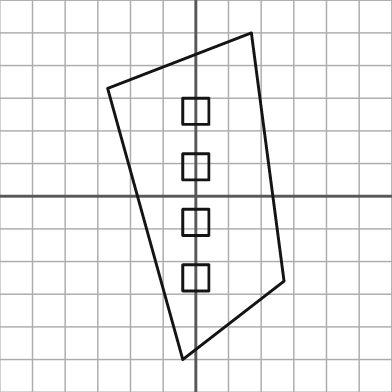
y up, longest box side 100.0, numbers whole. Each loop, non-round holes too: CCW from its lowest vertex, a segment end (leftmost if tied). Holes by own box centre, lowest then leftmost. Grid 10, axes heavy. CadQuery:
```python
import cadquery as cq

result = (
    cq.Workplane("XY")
    .moveTo(-4.0, -50.0)
    .lineTo(27.0, -26.0)
    .lineTo(17.0, 50.0)
    .lineTo(-27.0, 33.0)
    .close()
    .moveTo(-4.0, -29.0)
    .lineTo(4.0, -29.0)
    .lineTo(4.0, -21.0)
    .lineTo(-4.0, -21.0)
    .close()
    .moveTo(-4.0, -12.0)
    .lineTo(4.0, -12.0)
    .lineTo(4.0, -4.0)
    .lineTo(-4.0, -4.0)
    .close()
    .moveTo(-4.0, 5.0)
    .lineTo(4.0, 5.0)
    .lineTo(4.0, 13.0)
    .lineTo(-4.0, 13.0)
    .close()
    .moveTo(-4.0, 22.0)
    .lineTo(4.0, 22.0)
    .lineTo(4.0, 30.0)
    .lineTo(-4.0, 30.0)
    .close()
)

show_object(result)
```